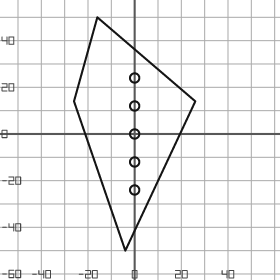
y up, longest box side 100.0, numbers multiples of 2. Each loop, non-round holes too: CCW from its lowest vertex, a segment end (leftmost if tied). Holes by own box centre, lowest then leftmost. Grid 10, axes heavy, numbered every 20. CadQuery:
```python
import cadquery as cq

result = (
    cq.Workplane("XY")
    .moveTo(-4.0, -50.0)
    .lineTo(26.0, 14.0)
    .lineTo(-16.0, 50.0)
    .lineTo(-26.0, 14.0)
    .close()
    .moveTo(0.0, -24.0)
    .circle(2.0)
    .moveTo(0.0, -12.0)
    .circle(2.0)
    .moveTo(0.0, 0.0)
    .circle(2.0)
    .moveTo(0.0, 12.0)
    .circle(2.0)
    .moveTo(0.0, 24.0)
    .circle(2.0)
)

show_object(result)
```